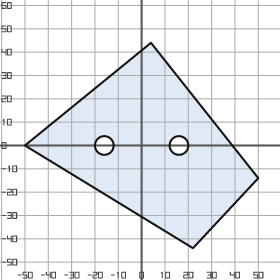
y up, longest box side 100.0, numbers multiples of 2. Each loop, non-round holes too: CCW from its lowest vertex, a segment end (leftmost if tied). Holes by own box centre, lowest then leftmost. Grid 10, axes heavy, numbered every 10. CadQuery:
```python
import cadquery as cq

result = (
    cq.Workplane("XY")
    .moveTo(22.0, -44.0)
    .lineTo(50.0, -14.0)
    .lineTo(4.0, 44.0)
    .lineTo(-50.0, 0.0)
    .close()
    .moveTo(-16.0, 0.0)
    .circle(4.0)
    .moveTo(16.0, 0.0)
    .circle(4.0)
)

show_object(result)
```